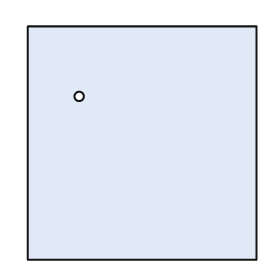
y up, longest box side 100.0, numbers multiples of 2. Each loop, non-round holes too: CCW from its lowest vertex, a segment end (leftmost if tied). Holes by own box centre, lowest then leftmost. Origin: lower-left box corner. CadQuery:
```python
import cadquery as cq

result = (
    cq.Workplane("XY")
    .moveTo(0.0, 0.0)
    .lineTo(98.0, 0.0)
    .lineTo(98.0, 100.0)
    .lineTo(0.0, 100.0)
    .close()
    .moveTo(22.0, 70.0)
    .circle(2.0)
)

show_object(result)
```